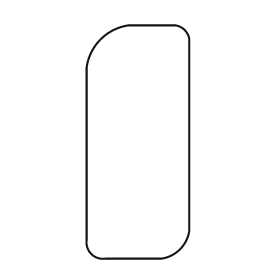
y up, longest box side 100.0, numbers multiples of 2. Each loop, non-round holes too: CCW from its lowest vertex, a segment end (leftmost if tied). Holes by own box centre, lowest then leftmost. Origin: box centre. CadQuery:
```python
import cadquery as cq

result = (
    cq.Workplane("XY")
    .moveTo(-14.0, -50.0)
    .lineTo(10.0, -50.0)
    .threePointArc((18.0, -46.0), (22.0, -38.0))
    .lineTo(22.0, 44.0)
    .threePointArc((20.0, 48.0), (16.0, 50.0))
    .lineTo(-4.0, 50.0)
    .threePointArc((-16.0, 44.0), (-22.0, 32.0))
    .lineTo(-22.0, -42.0)
    .threePointArc((-20.0, -48.0), (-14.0, -50.0))
    .close()
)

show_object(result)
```